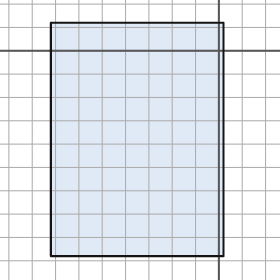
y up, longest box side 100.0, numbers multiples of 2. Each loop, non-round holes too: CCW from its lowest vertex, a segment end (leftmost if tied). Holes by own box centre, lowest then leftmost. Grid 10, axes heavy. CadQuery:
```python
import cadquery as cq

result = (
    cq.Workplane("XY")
    .moveTo(-72.0, -88.0)
    .lineTo(2.0, -88.0)
    .lineTo(2.0, 12.0)
    .lineTo(-72.0, 12.0)
    .close()
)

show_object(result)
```